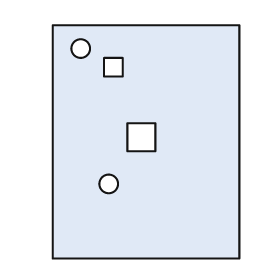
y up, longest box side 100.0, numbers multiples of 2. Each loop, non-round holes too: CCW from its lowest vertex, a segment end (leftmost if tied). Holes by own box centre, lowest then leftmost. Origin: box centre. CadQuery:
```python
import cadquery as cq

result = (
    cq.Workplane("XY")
    .moveTo(-40.0, -50.0)
    .lineTo(40.0, -50.0)
    .lineTo(40.0, 50.0)
    .lineTo(-40.0, 50.0)
    .close()
    .moveTo(-16.0, -18.0)
    .circle(4.0)
    .moveTo(-8.0, -4.0)
    .lineTo(4.0, -4.0)
    .lineTo(4.0, 8.0)
    .lineTo(-8.0, 8.0)
    .close()
    .moveTo(-18.0, 28.0)
    .lineTo(-10.0, 28.0)
    .lineTo(-10.0, 36.0)
    .lineTo(-18.0, 36.0)
    .close()
    .moveTo(-28.0, 40.0)
    .circle(4.0)
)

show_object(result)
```